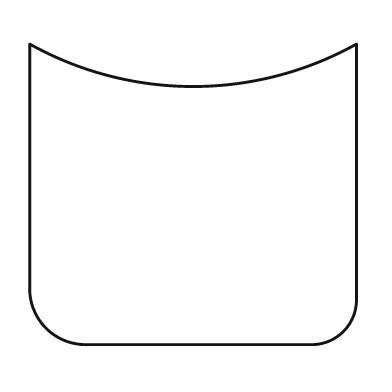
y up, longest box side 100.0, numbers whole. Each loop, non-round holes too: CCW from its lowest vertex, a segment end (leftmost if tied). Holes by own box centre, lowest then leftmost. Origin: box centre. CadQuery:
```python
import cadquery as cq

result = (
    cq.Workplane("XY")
    .moveTo(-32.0, -46.0)
    .lineTo(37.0, -46.0)
    .threePointArc((46.0, -42.0), (50.0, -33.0))
    .lineTo(50.0, 46.0)
    .threePointArc((0.0, 33.0), (-50.0, 46.0))
    .lineTo(-50.0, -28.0)
    .threePointArc((-45.0, -41.0), (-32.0, -46.0))
    .close()
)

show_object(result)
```